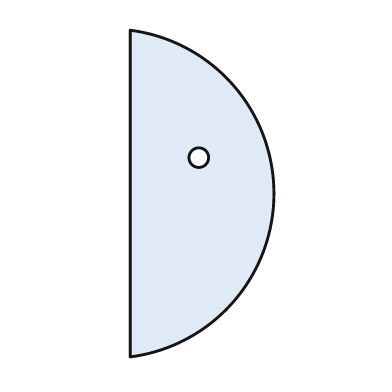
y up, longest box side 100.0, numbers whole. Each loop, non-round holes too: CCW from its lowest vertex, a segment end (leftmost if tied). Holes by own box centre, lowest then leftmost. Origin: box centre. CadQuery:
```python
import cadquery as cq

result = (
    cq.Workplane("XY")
    .moveTo(-22.0, -50.0)
    .threePointArc((22.0, 0.0), (-22.0, 50.0))
    .close()
    .moveTo(-1.0, 11.0)
    .circle(3.0)
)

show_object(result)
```